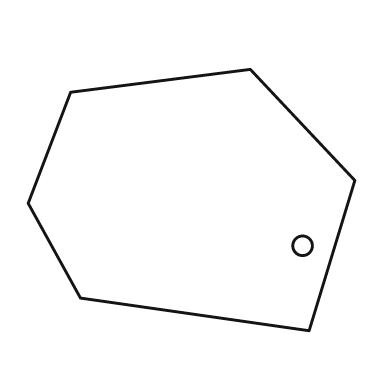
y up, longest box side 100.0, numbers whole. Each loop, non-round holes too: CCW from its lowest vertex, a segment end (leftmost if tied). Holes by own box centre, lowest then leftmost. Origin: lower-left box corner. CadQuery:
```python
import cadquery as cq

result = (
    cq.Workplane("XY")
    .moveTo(86.0, 0.0)
    .lineTo(100.0, 46.0)
    .lineTo(68.0, 80.0)
    .lineTo(13.0, 73.0)
    .lineTo(0.0, 39.0)
    .lineTo(16.0, 10.0)
    .close()
    .moveTo(84.0, 26.0)
    .circle(3.0)
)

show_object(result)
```